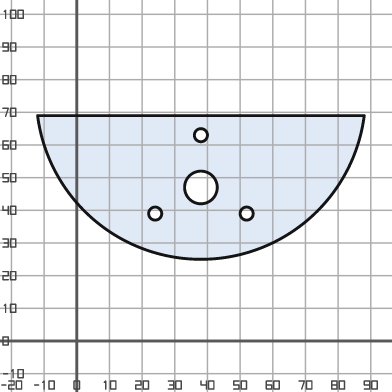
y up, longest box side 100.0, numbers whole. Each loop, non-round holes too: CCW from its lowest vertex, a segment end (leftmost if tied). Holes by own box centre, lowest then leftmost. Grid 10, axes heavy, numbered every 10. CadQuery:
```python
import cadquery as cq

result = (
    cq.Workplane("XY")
    .moveTo(-12.0, 69.0)
    .threePointArc((38.0, 25.0), (88.0, 69.0))
    .close()
    .moveTo(24.0, 39.0)
    .circle(2.0)
    .moveTo(52.0, 39.0)
    .circle(2.0)
    .moveTo(38.0, 47.0)
    .circle(5.0)
    .moveTo(38.0, 63.0)
    .circle(2.0)
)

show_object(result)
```